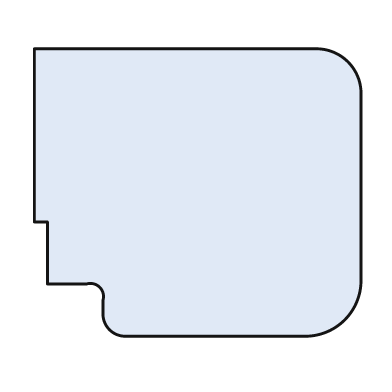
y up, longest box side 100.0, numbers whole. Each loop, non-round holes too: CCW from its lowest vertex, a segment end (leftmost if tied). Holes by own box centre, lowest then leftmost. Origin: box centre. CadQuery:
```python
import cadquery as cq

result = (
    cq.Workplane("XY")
    .moveTo(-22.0, -44.0)
    .lineTo(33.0, -44.0)
    .threePointArc((45.0, -39.0), (50.0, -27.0))
    .lineTo(50.0, 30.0)
    .threePointArc((46.0, 40.0), (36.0, 44.0))
    .lineTo(-50.0, 44.0)
    .lineTo(-50.0, -9.0)
    .lineTo(-46.0, -9.0)
    .lineTo(-46.0, -28.0)
    .lineTo(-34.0, -28.0)
    .threePointArc((-30.0, -29.0), (-29.0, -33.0))
    .lineTo(-29.0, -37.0)
    .threePointArc((-27.0, -42.0), (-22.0, -44.0))
    .close()
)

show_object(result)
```